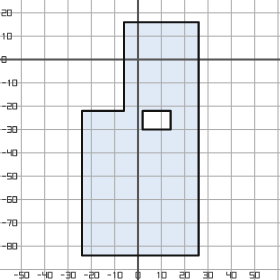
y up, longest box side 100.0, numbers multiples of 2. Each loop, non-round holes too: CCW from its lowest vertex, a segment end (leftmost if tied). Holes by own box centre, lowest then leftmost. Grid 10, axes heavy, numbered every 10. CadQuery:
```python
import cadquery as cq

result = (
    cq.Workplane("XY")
    .moveTo(-24.0, -84.0)
    .lineTo(26.0, -84.0)
    .lineTo(26.0, 16.0)
    .lineTo(-6.0, 16.0)
    .lineTo(-6.0, -22.0)
    .lineTo(-24.0, -22.0)
    .close()
    .moveTo(2.0, -30.0)
    .lineTo(14.0, -30.0)
    .lineTo(14.0, -22.0)
    .lineTo(2.0, -22.0)
    .close()
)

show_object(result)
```